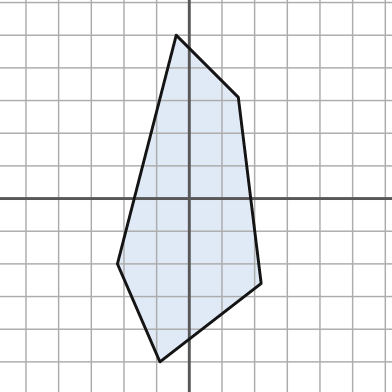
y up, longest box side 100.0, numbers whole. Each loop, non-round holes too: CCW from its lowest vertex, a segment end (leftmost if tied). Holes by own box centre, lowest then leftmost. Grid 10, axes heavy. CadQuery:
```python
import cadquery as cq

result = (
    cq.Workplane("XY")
    .moveTo(-9.0, -50.0)
    .lineTo(22.0, -26.0)
    .lineTo(15.0, 31.0)
    .lineTo(-4.0, 50.0)
    .lineTo(-22.0, -20.0)
    .close()
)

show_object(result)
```